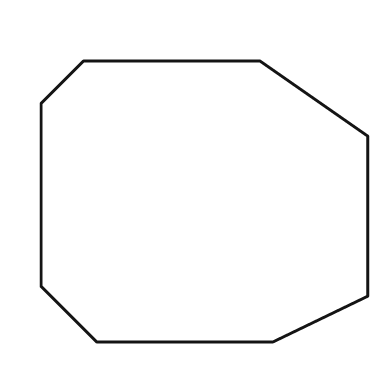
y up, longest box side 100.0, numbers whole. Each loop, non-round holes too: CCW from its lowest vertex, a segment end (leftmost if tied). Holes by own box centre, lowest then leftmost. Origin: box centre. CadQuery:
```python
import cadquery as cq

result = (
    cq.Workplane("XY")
    .moveTo(-33.0, -43.0)
    .lineTo(21.0, -43.0)
    .lineTo(50.0, -29.0)
    .lineTo(50.0, 20.0)
    .lineTo(17.0, 43.0)
    .lineTo(-37.0, 43.0)
    .lineTo(-50.0, 30.0)
    .lineTo(-50.0, -26.0)
    .close()
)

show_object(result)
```